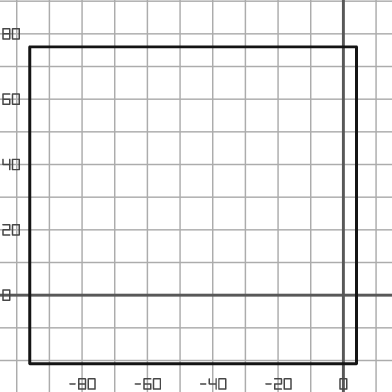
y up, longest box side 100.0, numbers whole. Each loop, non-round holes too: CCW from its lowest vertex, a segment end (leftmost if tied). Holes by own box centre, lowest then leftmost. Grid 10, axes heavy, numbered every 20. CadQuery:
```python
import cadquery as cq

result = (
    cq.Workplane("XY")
    .moveTo(-96.0, -21.0)
    .lineTo(4.0, -21.0)
    .lineTo(4.0, 76.0)
    .lineTo(-96.0, 76.0)
    .close()
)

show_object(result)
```